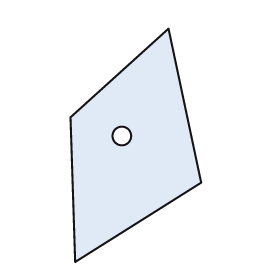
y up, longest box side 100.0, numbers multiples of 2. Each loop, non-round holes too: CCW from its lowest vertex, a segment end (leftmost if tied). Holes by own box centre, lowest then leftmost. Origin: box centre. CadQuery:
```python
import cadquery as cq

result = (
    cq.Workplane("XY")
    .moveTo(-26.0, -50.0)
    .lineTo(28.0, -16.0)
    .lineTo(14.0, 50.0)
    .lineTo(-28.0, 12.0)
    .close()
    .moveTo(-6.0, 4.0)
    .circle(4.0)
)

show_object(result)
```